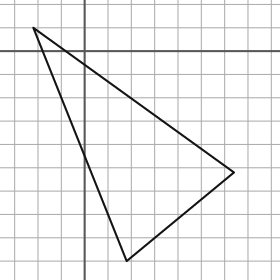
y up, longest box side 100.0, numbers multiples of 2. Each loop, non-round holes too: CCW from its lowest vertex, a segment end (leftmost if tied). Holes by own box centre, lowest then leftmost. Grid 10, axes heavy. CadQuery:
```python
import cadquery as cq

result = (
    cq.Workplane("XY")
    .moveTo(18.0, -90.0)
    .lineTo(64.0, -52.0)
    .lineTo(-22.0, 10.0)
    .close()
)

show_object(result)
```